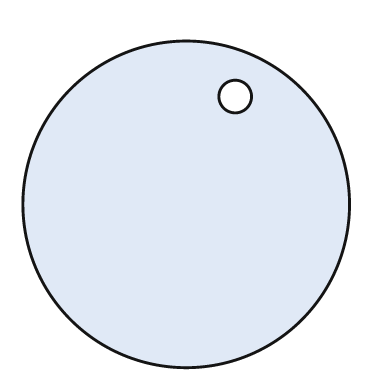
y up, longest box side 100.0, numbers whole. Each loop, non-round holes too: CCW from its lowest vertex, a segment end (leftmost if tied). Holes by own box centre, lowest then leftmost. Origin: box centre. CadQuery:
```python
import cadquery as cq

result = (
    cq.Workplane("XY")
    .moveTo(0.0, 0.0)
    .circle(50.0)
    .moveTo(15.0, 33.0)
    .circle(5.0)
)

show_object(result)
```